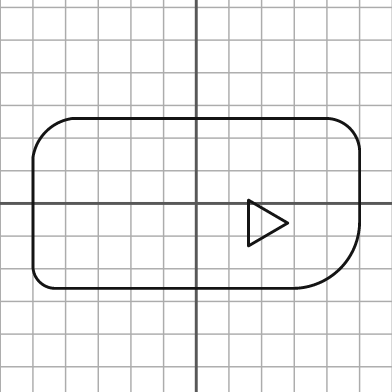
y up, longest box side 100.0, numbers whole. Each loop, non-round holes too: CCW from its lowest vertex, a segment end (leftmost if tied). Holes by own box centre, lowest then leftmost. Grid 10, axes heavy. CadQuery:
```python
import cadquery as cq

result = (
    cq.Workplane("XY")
    .moveTo(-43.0, -26.0)
    .lineTo(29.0, -26.0)
    .threePointArc((44.0, -20.0), (50.0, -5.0))
    .lineTo(50.0, 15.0)
    .threePointArc((47.0, 23.0), (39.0, 26.0))
    .lineTo(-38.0, 26.0)
    .threePointArc((-46.0, 22.0), (-50.0, 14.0))
    .lineTo(-50.0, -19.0)
    .threePointArc((-48.0, -24.0), (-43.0, -26.0))
    .close()
    .moveTo(16.0, -13.0)
    .lineTo(28.0, -6.0)
    .lineTo(16.0, 1.0)
    .close()
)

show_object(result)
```